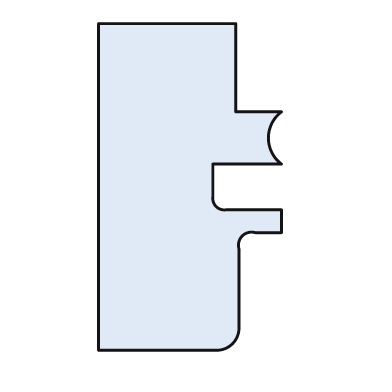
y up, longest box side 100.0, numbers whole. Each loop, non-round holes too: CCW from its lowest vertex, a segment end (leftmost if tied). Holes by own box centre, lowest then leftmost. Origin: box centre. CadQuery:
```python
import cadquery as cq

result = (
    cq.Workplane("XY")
    .moveTo(-28.0, -50.0)
    .lineTo(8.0, -50.0)
    .threePointArc((13.0, -48.0), (15.0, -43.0))
    .lineTo(15.0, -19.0)
    .threePointArc((16.0, -15.0), (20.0, -14.0))
    .lineTo(28.0, -14.0)
    .lineTo(28.0, -7.0)
    .lineTo(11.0, -7.0)
    .threePointArc((8.0, -6.0), (7.0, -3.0))
    .lineTo(7.0, 7.0)
    .lineTo(28.0, 7.0)
    .threePointArc((24.0, 15.0), (28.0, 23.0))
    .lineTo(14.0, 23.0)
    .lineTo(14.0, 50.0)
    .lineTo(-28.0, 50.0)
    .close()
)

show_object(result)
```